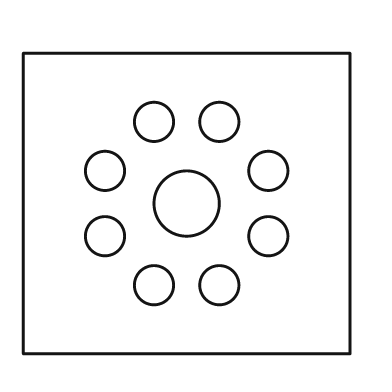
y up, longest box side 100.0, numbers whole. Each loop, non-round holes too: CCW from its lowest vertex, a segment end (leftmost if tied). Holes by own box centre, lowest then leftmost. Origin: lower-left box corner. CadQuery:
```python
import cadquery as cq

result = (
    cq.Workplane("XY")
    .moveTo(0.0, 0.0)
    .lineTo(100.0, 0.0)
    .lineTo(100.0, 92.0)
    .lineTo(0.0, 92.0)
    .close()
    .moveTo(40.0, 21.0)
    .circle(6.0)
    .moveTo(60.0, 21.0)
    .circle(6.0)
    .moveTo(25.0, 36.0)
    .circle(6.0)
    .moveTo(75.0, 36.0)
    .circle(6.0)
    .moveTo(50.0, 46.0)
    .circle(10.0)
    .moveTo(25.0, 56.0)
    .circle(6.0)
    .moveTo(75.0, 56.0)
    .circle(6.0)
    .moveTo(40.0, 71.0)
    .circle(6.0)
    .moveTo(60.0, 71.0)
    .circle(6.0)
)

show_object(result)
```